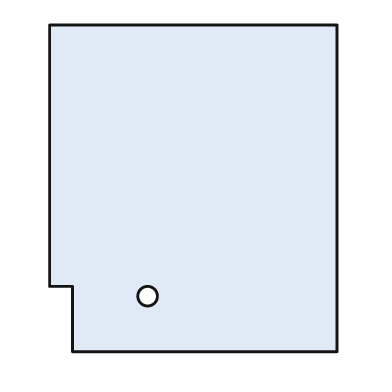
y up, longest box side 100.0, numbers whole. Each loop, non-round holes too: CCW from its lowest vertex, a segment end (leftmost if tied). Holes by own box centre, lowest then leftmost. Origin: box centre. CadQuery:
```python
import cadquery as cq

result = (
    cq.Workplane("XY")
    .moveTo(-37.0, -50.0)
    .lineTo(44.0, -50.0)
    .lineTo(44.0, 50.0)
    .lineTo(-44.0, 50.0)
    .lineTo(-44.0, -30.0)
    .lineTo(-37.0, -30.0)
    .close()
    .moveTo(-14.0, -33.0)
    .circle(3.0)
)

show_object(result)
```